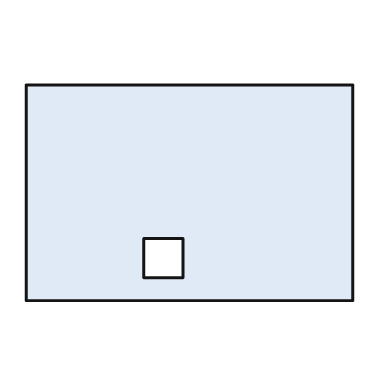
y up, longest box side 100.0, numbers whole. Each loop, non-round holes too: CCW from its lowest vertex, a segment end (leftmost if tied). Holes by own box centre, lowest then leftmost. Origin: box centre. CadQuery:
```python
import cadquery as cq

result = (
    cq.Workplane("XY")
    .moveTo(-50.0, -33.0)
    .lineTo(50.0, -33.0)
    .lineTo(50.0, 33.0)
    .lineTo(-50.0, 33.0)
    .close()
    .moveTo(-14.0, -26.0)
    .lineTo(-2.0, -26.0)
    .lineTo(-2.0, -14.0)
    .lineTo(-14.0, -14.0)
    .close()
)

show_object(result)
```